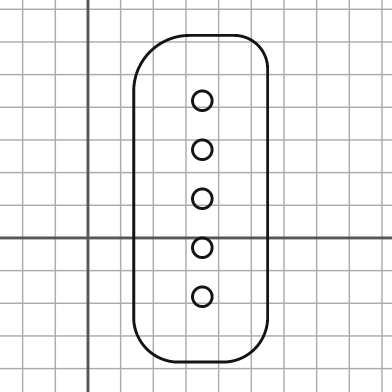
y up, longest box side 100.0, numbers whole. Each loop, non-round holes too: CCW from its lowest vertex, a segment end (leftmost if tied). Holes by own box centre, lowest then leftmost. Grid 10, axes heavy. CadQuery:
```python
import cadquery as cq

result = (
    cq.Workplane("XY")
    .moveTo(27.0, -38.0)
    .lineTo(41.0, -38.0)
    .threePointArc((51.0, -34.0), (55.0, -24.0))
    .lineTo(55.0, 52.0)
    .threePointArc((52.0, 59.0), (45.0, 62.0))
    .lineTo(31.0, 62.0)
    .threePointArc((19.0, 57.0), (14.0, 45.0))
    .lineTo(14.0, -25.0)
    .threePointArc((18.0, -34.0), (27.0, -38.0))
    .close()
    .moveTo(35.0, -18.0)
    .circle(3.0)
    .moveTo(35.0, -3.0)
    .circle(3.0)
    .moveTo(35.0, 12.0)
    .circle(3.0)
    .moveTo(35.0, 27.0)
    .circle(3.0)
    .moveTo(35.0, 42.0)
    .circle(3.0)
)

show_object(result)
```